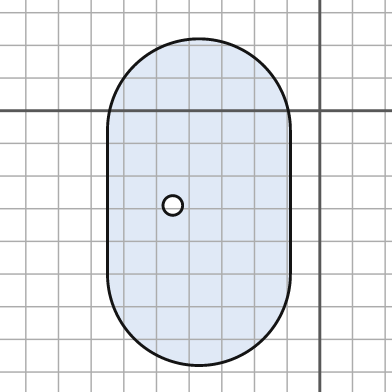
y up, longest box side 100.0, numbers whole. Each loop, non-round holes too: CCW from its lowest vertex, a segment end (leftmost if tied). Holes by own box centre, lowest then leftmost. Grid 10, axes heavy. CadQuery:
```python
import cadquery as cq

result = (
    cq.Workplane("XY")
    .moveTo(-65.0, -50.0)
    .threePointArc((-37.0, -78.0), (-9.0, -50.0))
    .lineTo(-9.0, -6.0)
    .threePointArc((-37.0, 22.0), (-65.0, -6.0))
    .close()
    .moveTo(-45.0, -29.0)
    .circle(3.0)
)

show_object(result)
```